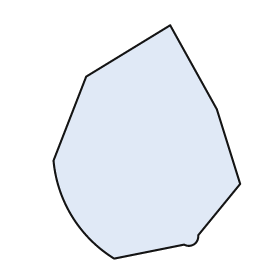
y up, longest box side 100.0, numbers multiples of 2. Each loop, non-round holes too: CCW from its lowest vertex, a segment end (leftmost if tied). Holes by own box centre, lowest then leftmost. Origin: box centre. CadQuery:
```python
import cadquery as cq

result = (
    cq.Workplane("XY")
    .moveTo(-14.0, -50.0)
    .lineTo(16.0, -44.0)
    .threePointArc((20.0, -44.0), (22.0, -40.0))
    .lineTo(40.0, -18.0)
    .lineTo(30.0, 14.0)
    .lineTo(10.0, 50.0)
    .lineTo(-26.0, 28.0)
    .lineTo(-40.0, -8.0)
    .threePointArc((-32.0, -32.0), (-14.0, -50.0))
    .close()
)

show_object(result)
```